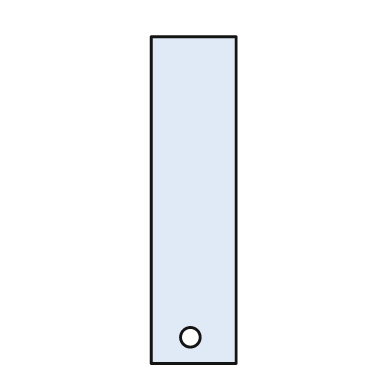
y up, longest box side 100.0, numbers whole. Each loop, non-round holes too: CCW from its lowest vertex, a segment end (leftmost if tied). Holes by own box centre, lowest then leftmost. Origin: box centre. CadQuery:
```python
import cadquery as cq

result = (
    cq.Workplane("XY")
    .moveTo(-13.0, -50.0)
    .lineTo(13.0, -50.0)
    .lineTo(13.0, 50.0)
    .lineTo(-13.0, 50.0)
    .close()
    .moveTo(-1.0, -42.0)
    .circle(3.0)
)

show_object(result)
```